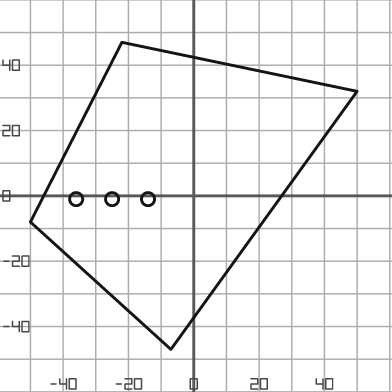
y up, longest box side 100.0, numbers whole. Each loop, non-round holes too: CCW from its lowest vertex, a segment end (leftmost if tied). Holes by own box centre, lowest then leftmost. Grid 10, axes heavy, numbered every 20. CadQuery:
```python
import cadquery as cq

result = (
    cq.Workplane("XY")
    .moveTo(-7.0, -47.0)
    .lineTo(50.0, 32.0)
    .lineTo(-22.0, 47.0)
    .lineTo(-50.0, -8.0)
    .close()
    .moveTo(-36.0, -1.0)
    .circle(2.0)
    .moveTo(-25.0, -1.0)
    .circle(2.0)
    .moveTo(-14.0, -1.0)
    .circle(2.0)
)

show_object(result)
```